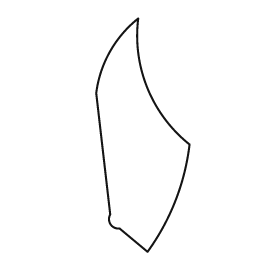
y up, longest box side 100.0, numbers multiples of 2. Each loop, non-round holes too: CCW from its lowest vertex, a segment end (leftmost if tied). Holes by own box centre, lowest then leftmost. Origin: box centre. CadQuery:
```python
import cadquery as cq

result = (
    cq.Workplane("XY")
    .moveTo(2.0, -50.0)
    .threePointArc((14.0, -28.0), (20.0, -4.0))
    .threePointArc((2.0, 20.0), (-2.0, 50.0))
    .threePointArc((-14.0, 36.0), (-20.0, 18.0))
    .lineTo(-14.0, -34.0)
    .threePointArc((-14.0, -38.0), (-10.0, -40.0))
    .close()
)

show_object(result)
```